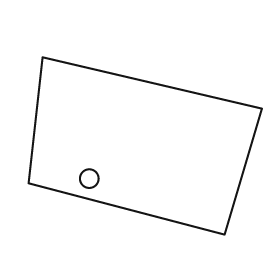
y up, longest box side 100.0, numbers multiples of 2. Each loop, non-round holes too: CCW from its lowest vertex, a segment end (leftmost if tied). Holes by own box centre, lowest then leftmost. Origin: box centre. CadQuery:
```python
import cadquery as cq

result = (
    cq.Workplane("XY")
    .moveTo(34.0, -38.0)
    .lineTo(50.0, 16.0)
    .lineTo(-44.0, 38.0)
    .lineTo(-50.0, -16.0)
    .close()
    .moveTo(-24.0, -14.0)
    .circle(4.0)
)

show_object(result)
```